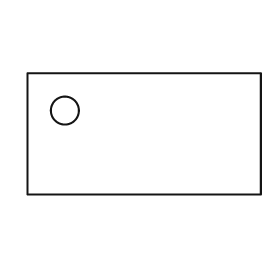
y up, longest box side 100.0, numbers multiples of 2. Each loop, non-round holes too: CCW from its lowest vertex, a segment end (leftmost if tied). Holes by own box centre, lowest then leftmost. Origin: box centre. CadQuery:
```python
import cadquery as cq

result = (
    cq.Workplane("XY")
    .moveTo(-50.0, -26.0)
    .lineTo(50.0, -26.0)
    .lineTo(50.0, 26.0)
    .lineTo(-50.0, 26.0)
    .close()
    .moveTo(-34.0, 10.0)
    .circle(6.0)
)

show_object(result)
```